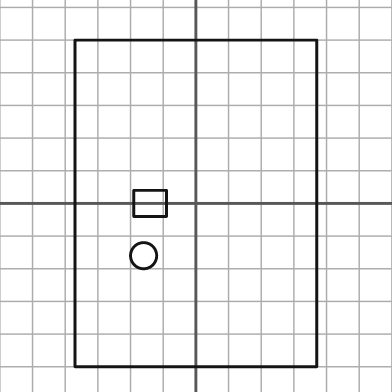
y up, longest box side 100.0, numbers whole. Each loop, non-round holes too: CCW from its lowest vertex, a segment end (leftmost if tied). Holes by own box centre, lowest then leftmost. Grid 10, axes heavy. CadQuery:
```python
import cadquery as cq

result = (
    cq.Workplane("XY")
    .moveTo(-37.0, -50.0)
    .lineTo(37.0, -50.0)
    .lineTo(37.0, 50.0)
    .lineTo(-37.0, 50.0)
    .close()
    .moveTo(-16.0, -16.0)
    .circle(4.0)
    .moveTo(-19.0, -4.0)
    .lineTo(-9.0, -4.0)
    .lineTo(-9.0, 4.0)
    .lineTo(-19.0, 4.0)
    .close()
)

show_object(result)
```